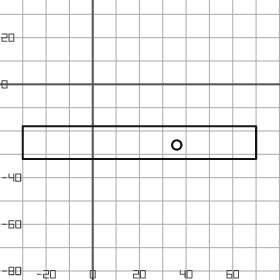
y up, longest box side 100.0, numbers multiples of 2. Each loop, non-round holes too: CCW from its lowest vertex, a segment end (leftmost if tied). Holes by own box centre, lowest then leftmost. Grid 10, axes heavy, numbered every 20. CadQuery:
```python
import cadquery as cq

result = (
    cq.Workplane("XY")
    .moveTo(-30.0, -32.0)
    .lineTo(70.0, -32.0)
    .lineTo(70.0, -18.0)
    .lineTo(-30.0, -18.0)
    .close()
    .moveTo(36.0, -26.0)
    .circle(2.0)
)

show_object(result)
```